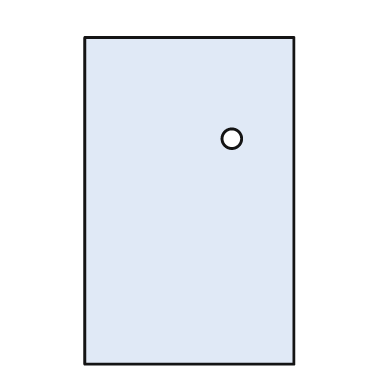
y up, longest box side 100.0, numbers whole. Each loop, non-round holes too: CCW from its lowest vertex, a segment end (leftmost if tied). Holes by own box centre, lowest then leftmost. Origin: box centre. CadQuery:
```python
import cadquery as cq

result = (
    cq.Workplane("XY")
    .moveTo(-32.0, -50.0)
    .lineTo(32.0, -50.0)
    .lineTo(32.0, 50.0)
    .lineTo(-32.0, 50.0)
    .close()
    .moveTo(13.0, 19.0)
    .circle(3.0)
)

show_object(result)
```